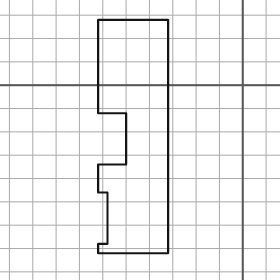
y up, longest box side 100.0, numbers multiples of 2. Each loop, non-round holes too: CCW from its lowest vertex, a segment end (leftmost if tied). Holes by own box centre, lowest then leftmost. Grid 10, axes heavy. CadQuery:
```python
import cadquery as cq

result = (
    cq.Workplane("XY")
    .moveTo(-62.0, -72.0)
    .lineTo(-32.0, -72.0)
    .lineTo(-32.0, 28.0)
    .lineTo(-62.0, 28.0)
    .lineTo(-62.0, -12.0)
    .lineTo(-50.0, -12.0)
    .lineTo(-50.0, -34.0)
    .lineTo(-62.0, -34.0)
    .lineTo(-62.0, -46.0)
    .lineTo(-58.0, -46.0)
    .lineTo(-58.0, -68.0)
    .lineTo(-62.0, -68.0)
    .close()
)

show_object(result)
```